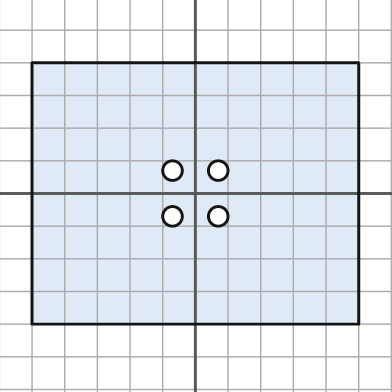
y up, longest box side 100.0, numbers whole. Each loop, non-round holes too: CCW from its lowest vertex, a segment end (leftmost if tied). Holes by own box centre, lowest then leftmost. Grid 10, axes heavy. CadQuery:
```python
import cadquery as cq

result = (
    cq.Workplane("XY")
    .moveTo(-50.0, -40.0)
    .lineTo(50.0, -40.0)
    .lineTo(50.0, 40.0)
    .lineTo(-50.0, 40.0)
    .close()
    .moveTo(-7.0, -7.0)
    .circle(3.0)
    .moveTo(7.0, -7.0)
    .circle(3.0)
    .moveTo(-7.0, 7.0)
    .circle(3.0)
    .moveTo(7.0, 7.0)
    .circle(3.0)
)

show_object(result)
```